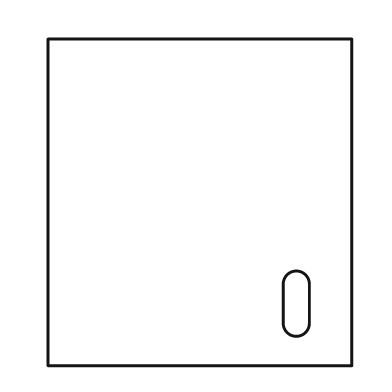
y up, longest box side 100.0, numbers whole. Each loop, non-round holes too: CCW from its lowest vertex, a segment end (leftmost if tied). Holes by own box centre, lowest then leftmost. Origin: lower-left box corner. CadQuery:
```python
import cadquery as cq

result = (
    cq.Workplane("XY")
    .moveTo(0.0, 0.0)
    .lineTo(93.0, 0.0)
    .lineTo(93.0, 100.0)
    .lineTo(0.0, 100.0)
    .close()
    .moveTo(72.0, 13.0)
    .threePointArc((76.0, 9.0), (80.0, 13.0))
    .lineTo(80.0, 25.0)
    .threePointArc((76.0, 29.0), (72.0, 25.0))
    .close()
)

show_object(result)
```